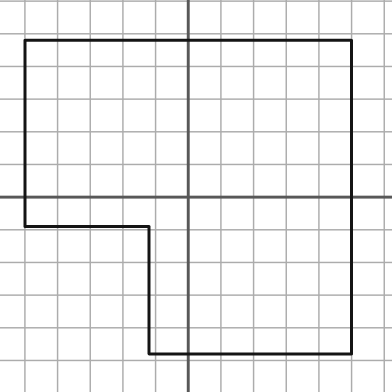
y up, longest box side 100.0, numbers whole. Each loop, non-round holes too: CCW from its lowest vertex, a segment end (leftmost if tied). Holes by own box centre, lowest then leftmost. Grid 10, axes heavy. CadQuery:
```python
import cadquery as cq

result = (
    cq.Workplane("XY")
    .moveTo(-12.0, -48.0)
    .lineTo(50.0, -48.0)
    .lineTo(50.0, 48.0)
    .lineTo(-50.0, 48.0)
    .lineTo(-50.0, -9.0)
    .lineTo(-12.0, -9.0)
    .close()
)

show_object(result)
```